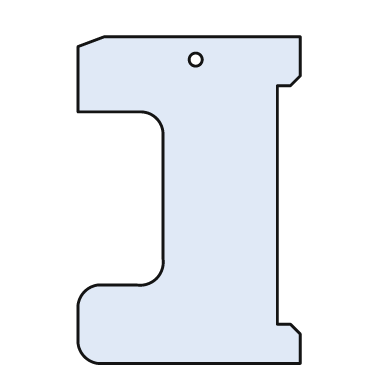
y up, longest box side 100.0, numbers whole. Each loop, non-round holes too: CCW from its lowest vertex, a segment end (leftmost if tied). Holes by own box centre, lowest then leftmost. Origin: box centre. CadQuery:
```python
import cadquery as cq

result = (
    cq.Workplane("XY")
    .moveTo(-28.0, -50.0)
    .lineTo(34.0, -50.0)
    .lineTo(34.0, -41.0)
    .lineTo(31.0, -38.0)
    .lineTo(27.0, -38.0)
    .lineTo(27.0, 35.0)
    .lineTo(31.0, 35.0)
    .lineTo(34.0, 38.0)
    .lineTo(34.0, 50.0)
    .lineTo(-26.0, 50.0)
    .lineTo(-34.0, 47.0)
    .lineTo(-34.0, 27.0)
    .lineTo(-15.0, 27.0)
    .threePointArc((-10.0, 25.0), (-8.0, 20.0))
    .lineTo(-8.0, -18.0)
    .threePointArc((-10.0, -24.0), (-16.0, -26.0))
    .lineTo(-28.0, -26.0)
    .threePointArc((-32.0, -28.0), (-34.0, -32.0))
    .lineTo(-34.0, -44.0)
    .threePointArc((-32.0, -48.0), (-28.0, -50.0))
    .close()
    .moveTo(2.0, 43.0)
    .circle(2.0)
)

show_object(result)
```